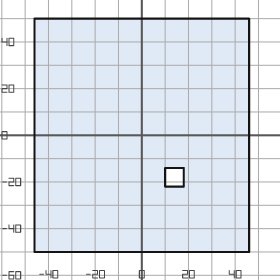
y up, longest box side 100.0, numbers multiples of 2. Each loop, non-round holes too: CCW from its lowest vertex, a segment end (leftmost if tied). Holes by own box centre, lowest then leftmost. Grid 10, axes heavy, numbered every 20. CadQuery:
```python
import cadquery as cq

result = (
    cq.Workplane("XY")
    .moveTo(-46.0, -50.0)
    .lineTo(46.0, -50.0)
    .lineTo(46.0, 50.0)
    .lineTo(-46.0, 50.0)
    .close()
    .moveTo(10.0, -22.0)
    .lineTo(18.0, -22.0)
    .lineTo(18.0, -14.0)
    .lineTo(10.0, -14.0)
    .close()
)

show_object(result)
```